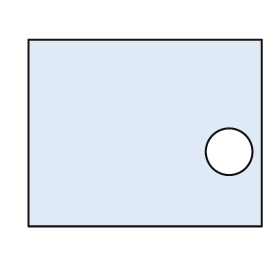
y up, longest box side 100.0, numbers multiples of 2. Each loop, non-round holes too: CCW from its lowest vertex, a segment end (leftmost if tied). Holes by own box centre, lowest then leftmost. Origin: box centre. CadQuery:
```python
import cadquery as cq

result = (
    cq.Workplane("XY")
    .moveTo(-50.0, -40.0)
    .lineTo(50.0, -40.0)
    .lineTo(50.0, 40.0)
    .lineTo(-50.0, 40.0)
    .close()
    .moveTo(36.0, -8.0)
    .circle(10.0)
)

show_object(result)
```